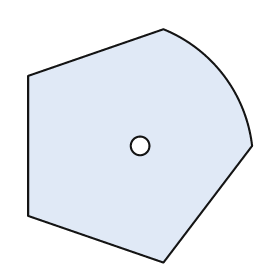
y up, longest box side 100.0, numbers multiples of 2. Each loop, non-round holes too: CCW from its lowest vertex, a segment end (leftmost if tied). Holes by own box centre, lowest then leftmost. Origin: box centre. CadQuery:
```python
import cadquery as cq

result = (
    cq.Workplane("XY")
    .moveTo(10.0, -50.0)
    .lineTo(48.0, 0.0)
    .threePointArc((36.0, 30.0), (10.0, 50.0))
    .lineTo(-48.0, 30.0)
    .lineTo(-48.0, -30.0)
    .close()
    .moveTo(0.0, 0.0)
    .circle(4.0)
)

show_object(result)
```